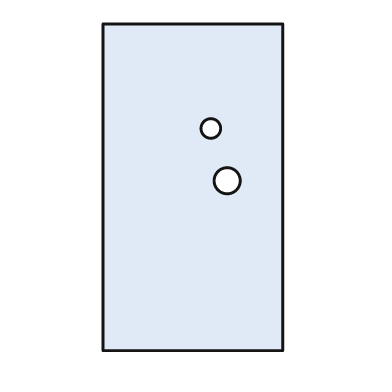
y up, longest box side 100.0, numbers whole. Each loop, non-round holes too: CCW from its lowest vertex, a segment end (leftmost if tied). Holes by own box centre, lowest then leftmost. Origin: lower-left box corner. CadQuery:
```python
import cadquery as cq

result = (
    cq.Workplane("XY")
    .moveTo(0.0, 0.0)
    .lineTo(55.0, 0.0)
    .lineTo(55.0, 100.0)
    .lineTo(0.0, 100.0)
    .close()
    .moveTo(38.0, 52.0)
    .circle(4.0)
    .moveTo(33.0, 68.0)
    .circle(3.0)
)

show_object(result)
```